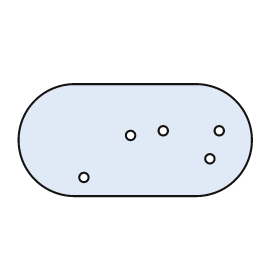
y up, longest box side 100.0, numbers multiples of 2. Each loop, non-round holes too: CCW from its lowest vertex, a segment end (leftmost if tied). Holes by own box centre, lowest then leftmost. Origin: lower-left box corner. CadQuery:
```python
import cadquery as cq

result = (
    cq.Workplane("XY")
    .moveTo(24.0, 0.0)
    .lineTo(76.0, 0.0)
    .threePointArc((100.0, 24.0), (76.0, 48.0))
    .lineTo(24.0, 48.0)
    .threePointArc((0.0, 24.0), (24.0, 0.0))
    .close()
    .moveTo(28.0, 8.0)
    .circle(2.0)
    .moveTo(82.0, 16.0)
    .circle(2.0)
    .moveTo(48.0, 26.0)
    .circle(2.0)
    .moveTo(62.0, 28.0)
    .circle(2.0)
    .moveTo(86.0, 28.0)
    .circle(2.0)
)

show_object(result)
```